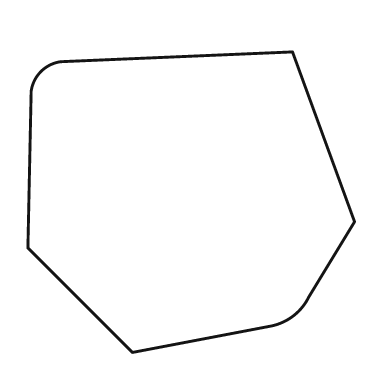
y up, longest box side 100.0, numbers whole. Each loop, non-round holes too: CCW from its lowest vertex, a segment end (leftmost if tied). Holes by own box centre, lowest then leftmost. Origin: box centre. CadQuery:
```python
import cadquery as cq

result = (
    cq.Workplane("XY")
    .moveTo(-18.0, -46.0)
    .lineTo(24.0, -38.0)
    .threePointArc((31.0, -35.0), (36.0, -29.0))
    .lineTo(50.0, -6.0)
    .lineTo(31.0, 46.0)
    .lineTo(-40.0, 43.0)
    .threePointArc((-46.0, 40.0), (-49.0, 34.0))
    .lineTo(-50.0, -14.0)
    .close()
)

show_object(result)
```